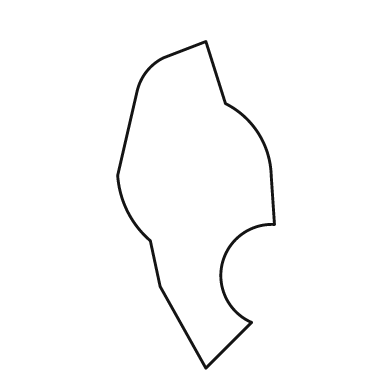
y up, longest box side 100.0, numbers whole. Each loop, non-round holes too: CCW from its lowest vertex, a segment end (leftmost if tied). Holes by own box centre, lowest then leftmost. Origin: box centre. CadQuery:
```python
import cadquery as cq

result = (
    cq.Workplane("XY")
    .moveTo(3.0, -50.0)
    .lineTo(17.0, -36.0)
    .threePointArc((8.0, -18.0), (24.0, -6.0))
    .lineTo(23.0, 9.0)
    .threePointArc((19.0, 22.0), (9.0, 31.0))
    .lineTo(3.0, 50.0)
    .lineTo(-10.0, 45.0)
    .threePointArc((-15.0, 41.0), (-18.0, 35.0))
    .lineTo(-24.0, 9.0)
    .threePointArc((-21.0, -2.0), (-14.0, -11.0))
    .lineTo(-11.0, -25.0)
    .close()
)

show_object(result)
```